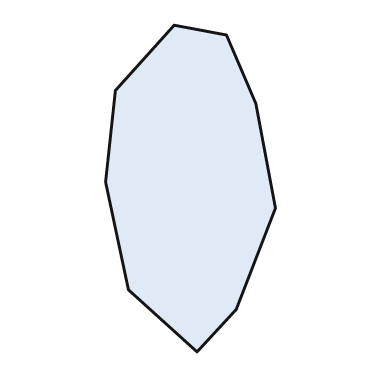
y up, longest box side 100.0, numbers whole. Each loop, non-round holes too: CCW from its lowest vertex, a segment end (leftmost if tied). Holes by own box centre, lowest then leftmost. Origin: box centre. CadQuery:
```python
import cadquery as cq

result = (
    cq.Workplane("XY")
    .moveTo(2.0, -50.0)
    .lineTo(14.0, -37.0)
    .lineTo(26.0, -6.0)
    .lineTo(20.0, 26.0)
    .lineTo(11.0, 47.0)
    .lineTo(-5.0, 50.0)
    .lineTo(-23.0, 30.0)
    .lineTo(-26.0, 2.0)
    .lineTo(-19.0, -31.0)
    .close()
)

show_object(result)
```